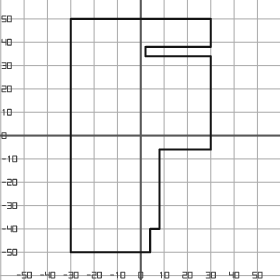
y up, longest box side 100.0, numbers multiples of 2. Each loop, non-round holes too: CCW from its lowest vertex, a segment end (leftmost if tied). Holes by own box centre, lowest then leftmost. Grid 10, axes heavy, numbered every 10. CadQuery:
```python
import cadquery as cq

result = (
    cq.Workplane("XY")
    .moveTo(-30.0, -50.0)
    .lineTo(4.0, -50.0)
    .lineTo(4.0, -40.0)
    .lineTo(8.0, -40.0)
    .lineTo(8.0, -6.0)
    .lineTo(30.0, -6.0)
    .lineTo(30.0, 34.0)
    .lineTo(2.0, 34.0)
    .lineTo(2.0, 38.0)
    .lineTo(30.0, 38.0)
    .lineTo(30.0, 50.0)
    .lineTo(-30.0, 50.0)
    .close()
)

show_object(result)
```